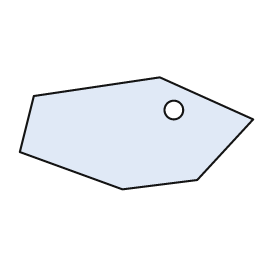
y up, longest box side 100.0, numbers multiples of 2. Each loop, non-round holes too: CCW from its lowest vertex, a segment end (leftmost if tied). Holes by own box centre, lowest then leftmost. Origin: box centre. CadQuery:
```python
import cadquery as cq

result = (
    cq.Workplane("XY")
    .moveTo(-6.0, -24.0)
    .lineTo(26.0, -20.0)
    .lineTo(50.0, 6.0)
    .lineTo(10.0, 24.0)
    .lineTo(-44.0, 16.0)
    .lineTo(-50.0, -8.0)
    .close()
    .moveTo(16.0, 10.0)
    .circle(4.0)
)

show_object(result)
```